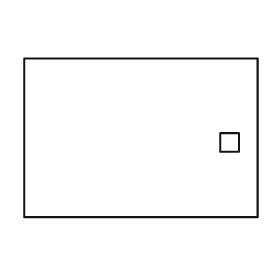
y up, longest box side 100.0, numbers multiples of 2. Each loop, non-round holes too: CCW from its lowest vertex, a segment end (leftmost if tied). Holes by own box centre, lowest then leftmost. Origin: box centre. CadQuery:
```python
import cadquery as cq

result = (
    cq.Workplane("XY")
    .moveTo(-50.0, -34.0)
    .lineTo(50.0, -34.0)
    .lineTo(50.0, 34.0)
    .lineTo(-50.0, 34.0)
    .close()
    .moveTo(34.0, -6.0)
    .lineTo(42.0, -6.0)
    .lineTo(42.0, 2.0)
    .lineTo(34.0, 2.0)
    .close()
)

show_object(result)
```